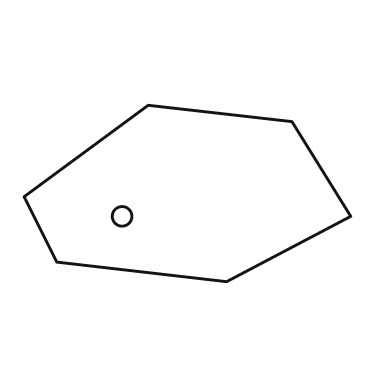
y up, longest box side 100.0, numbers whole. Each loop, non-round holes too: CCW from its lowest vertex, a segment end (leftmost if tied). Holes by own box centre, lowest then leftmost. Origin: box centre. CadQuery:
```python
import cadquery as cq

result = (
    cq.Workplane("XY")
    .moveTo(12.0, -27.0)
    .lineTo(50.0, -7.0)
    .lineTo(32.0, 22.0)
    .lineTo(-12.0, 27.0)
    .lineTo(-50.0, -1.0)
    .lineTo(-40.0, -21.0)
    .close()
    .moveTo(-20.0, -7.0)
    .circle(3.0)
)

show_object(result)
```